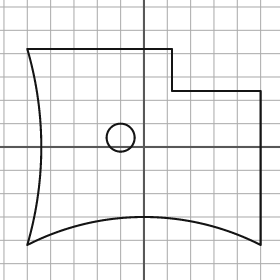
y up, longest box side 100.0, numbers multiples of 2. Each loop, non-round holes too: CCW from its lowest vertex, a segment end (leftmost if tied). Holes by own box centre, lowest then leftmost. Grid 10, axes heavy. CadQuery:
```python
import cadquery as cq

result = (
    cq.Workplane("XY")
    .moveTo(-50.0, -42.0)
    .threePointArc((0.0, -30.0), (50.0, -42.0))
    .lineTo(50.0, 24.0)
    .lineTo(12.0, 24.0)
    .lineTo(12.0, 42.0)
    .lineTo(-50.0, 42.0)
    .threePointArc((-44.0, 0.0), (-50.0, -42.0))
    .close()
    .moveTo(-10.0, 4.0)
    .circle(6.0)
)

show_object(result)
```